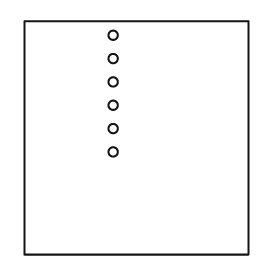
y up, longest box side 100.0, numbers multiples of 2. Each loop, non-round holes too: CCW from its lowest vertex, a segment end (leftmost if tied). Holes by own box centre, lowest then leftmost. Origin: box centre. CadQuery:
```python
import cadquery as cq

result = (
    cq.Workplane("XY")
    .moveTo(-48.0, -50.0)
    .lineTo(48.0, -50.0)
    .lineTo(48.0, 50.0)
    .lineTo(-48.0, 50.0)
    .close()
    .moveTo(-10.0, -6.0)
    .circle(2.0)
    .moveTo(-10.0, 4.0)
    .circle(2.0)
    .moveTo(-10.0, 14.0)
    .circle(2.0)
    .moveTo(-10.0, 24.0)
    .circle(2.0)
    .moveTo(-10.0, 34.0)
    .circle(2.0)
    .moveTo(-10.0, 44.0)
    .circle(2.0)
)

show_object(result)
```